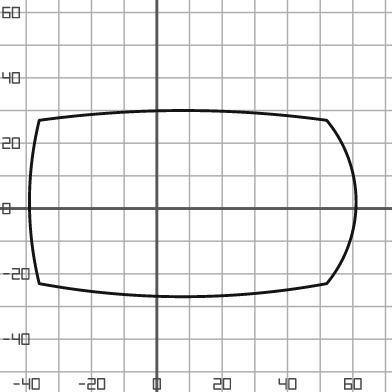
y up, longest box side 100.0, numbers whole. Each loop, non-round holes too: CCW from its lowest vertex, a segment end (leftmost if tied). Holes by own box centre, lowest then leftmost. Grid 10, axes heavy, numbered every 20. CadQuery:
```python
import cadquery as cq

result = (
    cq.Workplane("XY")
    .moveTo(-36.0, -23.0)
    .threePointArc((8.0, -27.0), (52.0, -23.0))
    .threePointArc((61.0, 2.0), (52.0, 27.0))
    .threePointArc((8.0, 30.0), (-36.0, 27.0))
    .threePointArc((-39.0, 2.0), (-36.0, -23.0))
    .close()
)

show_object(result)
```